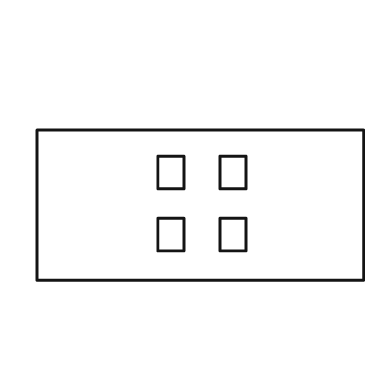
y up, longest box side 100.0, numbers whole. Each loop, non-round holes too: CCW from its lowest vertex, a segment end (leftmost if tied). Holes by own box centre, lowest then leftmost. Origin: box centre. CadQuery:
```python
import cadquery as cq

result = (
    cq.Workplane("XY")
    .moveTo(-50.0, -23.0)
    .lineTo(50.0, -23.0)
    .lineTo(50.0, 23.0)
    .lineTo(-50.0, 23.0)
    .close()
    .moveTo(-13.0, -14.0)
    .lineTo(-5.0, -14.0)
    .lineTo(-5.0, -4.0)
    .lineTo(-13.0, -4.0)
    .close()
    .moveTo(6.0, -14.0)
    .lineTo(14.0, -14.0)
    .lineTo(14.0, -4.0)
    .lineTo(6.0, -4.0)
    .close()
    .moveTo(-13.0, 5.0)
    .lineTo(-5.0, 5.0)
    .lineTo(-5.0, 15.0)
    .lineTo(-13.0, 15.0)
    .close()
    .moveTo(6.0, 5.0)
    .lineTo(14.0, 5.0)
    .lineTo(14.0, 15.0)
    .lineTo(6.0, 15.0)
    .close()
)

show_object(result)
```